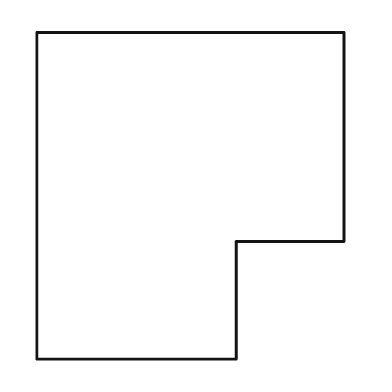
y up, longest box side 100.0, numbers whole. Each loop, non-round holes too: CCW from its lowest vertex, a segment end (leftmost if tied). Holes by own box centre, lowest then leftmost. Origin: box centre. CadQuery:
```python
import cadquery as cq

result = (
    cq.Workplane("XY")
    .moveTo(-47.0, -50.0)
    .lineTo(14.0, -50.0)
    .lineTo(14.0, -14.0)
    .lineTo(47.0, -14.0)
    .lineTo(47.0, 50.0)
    .lineTo(-47.0, 50.0)
    .close()
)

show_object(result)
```